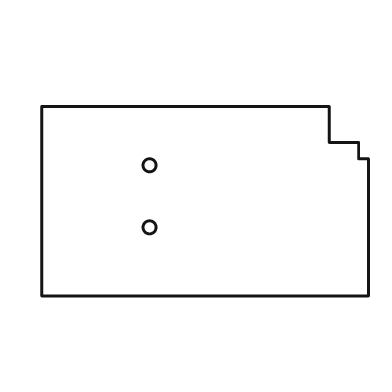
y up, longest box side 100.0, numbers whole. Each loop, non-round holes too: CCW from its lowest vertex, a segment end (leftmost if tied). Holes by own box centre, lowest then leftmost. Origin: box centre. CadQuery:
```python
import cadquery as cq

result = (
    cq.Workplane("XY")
    .moveTo(-50.0, -29.0)
    .lineTo(50.0, -29.0)
    .lineTo(50.0, 13.0)
    .lineTo(47.0, 13.0)
    .lineTo(47.0, 18.0)
    .lineTo(38.0, 18.0)
    .lineTo(38.0, 29.0)
    .lineTo(-50.0, 29.0)
    .close()
    .moveTo(-17.0, -8.0)
    .circle(2.0)
    .moveTo(-17.0, 11.0)
    .circle(2.0)
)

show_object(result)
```